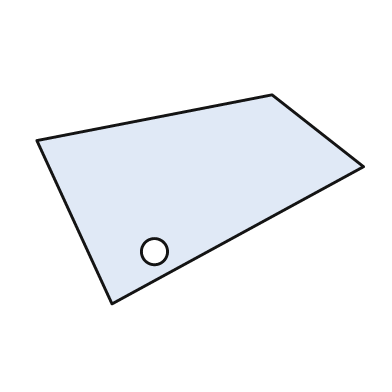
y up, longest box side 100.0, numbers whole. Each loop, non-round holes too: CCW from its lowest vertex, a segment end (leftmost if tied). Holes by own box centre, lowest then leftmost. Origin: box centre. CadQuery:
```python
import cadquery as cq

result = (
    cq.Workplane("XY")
    .moveTo(-27.0, -32.0)
    .lineTo(50.0, 10.0)
    .lineTo(22.0, 32.0)
    .lineTo(-50.0, 18.0)
    .close()
    .moveTo(-14.0, -16.0)
    .circle(4.0)
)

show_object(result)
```